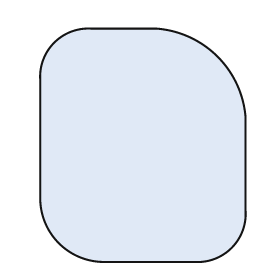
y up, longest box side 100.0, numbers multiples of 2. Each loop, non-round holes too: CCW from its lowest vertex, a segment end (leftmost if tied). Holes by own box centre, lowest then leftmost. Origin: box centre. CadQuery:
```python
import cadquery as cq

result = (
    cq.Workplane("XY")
    .moveTo(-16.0, -50.0)
    .lineTo(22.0, -50.0)
    .threePointArc((38.0, -44.0), (44.0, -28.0))
    .lineTo(44.0, 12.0)
    .threePointArc((32.0, 38.0), (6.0, 50.0))
    .lineTo(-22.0, 50.0)
    .threePointArc((-38.0, 44.0), (-44.0, 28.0))
    .lineTo(-44.0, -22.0)
    .threePointArc((-36.0, -42.0), (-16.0, -50.0))
    .close()
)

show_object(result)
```